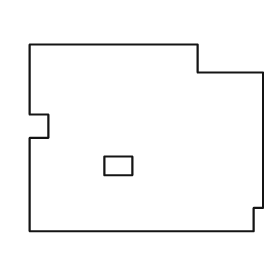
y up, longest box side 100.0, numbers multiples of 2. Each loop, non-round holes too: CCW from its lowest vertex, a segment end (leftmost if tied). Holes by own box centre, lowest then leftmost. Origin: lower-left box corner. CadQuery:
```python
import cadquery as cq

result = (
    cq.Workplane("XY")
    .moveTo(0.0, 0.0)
    .lineTo(96.0, 0.0)
    .lineTo(96.0, 10.0)
    .lineTo(100.0, 10.0)
    .lineTo(100.0, 68.0)
    .lineTo(72.0, 68.0)
    .lineTo(72.0, 80.0)
    .lineTo(0.0, 80.0)
    .lineTo(0.0, 50.0)
    .lineTo(8.0, 50.0)
    .lineTo(8.0, 40.0)
    .lineTo(0.0, 40.0)
    .close()
    .moveTo(32.0, 24.0)
    .lineTo(44.0, 24.0)
    .lineTo(44.0, 32.0)
    .lineTo(32.0, 32.0)
    .close()
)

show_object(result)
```